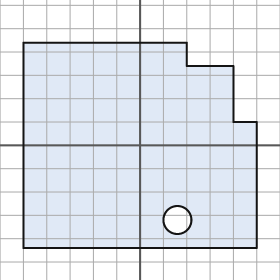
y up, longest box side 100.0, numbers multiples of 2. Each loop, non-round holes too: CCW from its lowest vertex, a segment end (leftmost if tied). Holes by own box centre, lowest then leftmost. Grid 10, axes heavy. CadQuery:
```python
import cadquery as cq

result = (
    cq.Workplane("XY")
    .moveTo(-50.0, -44.0)
    .lineTo(50.0, -44.0)
    .lineTo(50.0, 10.0)
    .lineTo(40.0, 10.0)
    .lineTo(40.0, 34.0)
    .lineTo(20.0, 34.0)
    .lineTo(20.0, 44.0)
    .lineTo(-50.0, 44.0)
    .close()
    .moveTo(16.0, -32.0)
    .circle(6.0)
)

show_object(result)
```